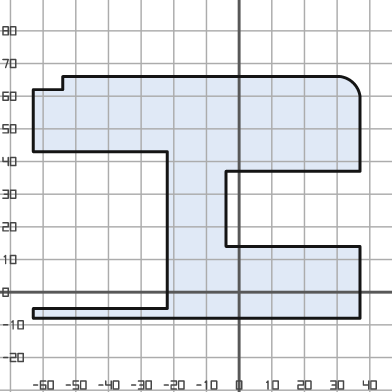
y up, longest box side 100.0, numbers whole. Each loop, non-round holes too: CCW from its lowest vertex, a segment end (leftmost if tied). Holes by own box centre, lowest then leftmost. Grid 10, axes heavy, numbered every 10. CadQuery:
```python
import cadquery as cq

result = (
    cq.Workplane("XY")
    .moveTo(-63.0, -8.0)
    .lineTo(37.0, -8.0)
    .lineTo(37.0, 14.0)
    .lineTo(-4.0, 14.0)
    .lineTo(-4.0, 37.0)
    .lineTo(37.0, 37.0)
    .lineTo(37.0, 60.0)
    .threePointArc((35.0, 64.0), (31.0, 66.0))
    .lineTo(-54.0, 66.0)
    .lineTo(-54.0, 62.0)
    .lineTo(-63.0, 62.0)
    .lineTo(-63.0, 43.0)
    .lineTo(-22.0, 43.0)
    .lineTo(-22.0, -5.0)
    .lineTo(-63.0, -5.0)
    .close()
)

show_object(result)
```